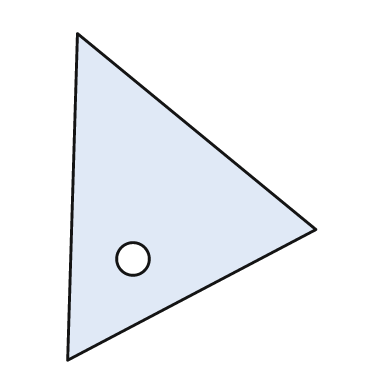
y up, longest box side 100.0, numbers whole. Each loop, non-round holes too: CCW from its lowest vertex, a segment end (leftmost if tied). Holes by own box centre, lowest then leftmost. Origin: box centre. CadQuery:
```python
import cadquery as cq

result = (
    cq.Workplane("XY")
    .moveTo(-38.0, -50.0)
    .lineTo(38.0, -10.0)
    .lineTo(-35.0, 50.0)
    .close()
    .moveTo(-18.0, -19.0)
    .circle(5.0)
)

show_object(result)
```